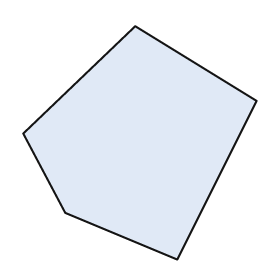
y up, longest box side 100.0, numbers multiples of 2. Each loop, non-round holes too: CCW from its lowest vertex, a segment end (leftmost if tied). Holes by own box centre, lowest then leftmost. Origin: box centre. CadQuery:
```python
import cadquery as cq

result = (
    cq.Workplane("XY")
    .moveTo(16.0, -50.0)
    .lineTo(50.0, 18.0)
    .lineTo(-2.0, 50.0)
    .lineTo(-50.0, 4.0)
    .lineTo(-32.0, -30.0)
    .close()
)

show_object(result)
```